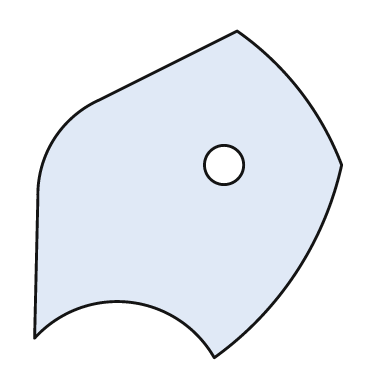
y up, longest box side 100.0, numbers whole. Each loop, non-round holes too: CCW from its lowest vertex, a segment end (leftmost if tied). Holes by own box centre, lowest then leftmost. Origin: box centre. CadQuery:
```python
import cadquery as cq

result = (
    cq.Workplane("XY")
    .moveTo(8.0, -50.0)
    .threePointArc((33.0, -24.0), (47.0, 9.0))
    .threePointArc((34.0, 32.0), (15.0, 50.0))
    .lineTo(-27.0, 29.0)
    .threePointArc((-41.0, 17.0), (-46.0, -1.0))
    .lineTo(-47.0, -44.0)
    .threePointArc((-18.0, -33.0), (8.0, -50.0))
    .close()
    .moveTo(11.0, 9.0)
    .circle(6.0)
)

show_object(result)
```